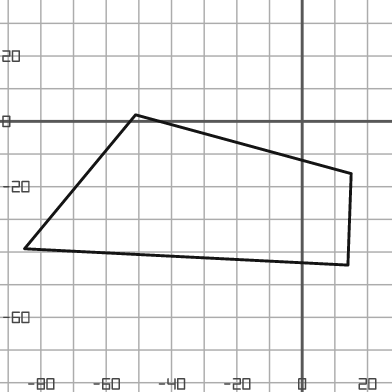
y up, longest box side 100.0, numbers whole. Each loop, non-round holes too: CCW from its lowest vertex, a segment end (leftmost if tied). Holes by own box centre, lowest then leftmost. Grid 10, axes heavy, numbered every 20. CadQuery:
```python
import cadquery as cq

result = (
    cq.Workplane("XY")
    .moveTo(14.0, -44.0)
    .lineTo(15.0, -16.0)
    .lineTo(-51.0, 2.0)
    .lineTo(-85.0, -39.0)
    .close()
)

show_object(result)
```